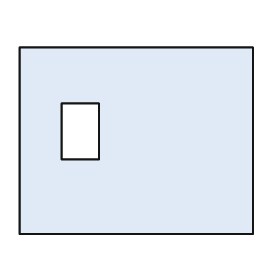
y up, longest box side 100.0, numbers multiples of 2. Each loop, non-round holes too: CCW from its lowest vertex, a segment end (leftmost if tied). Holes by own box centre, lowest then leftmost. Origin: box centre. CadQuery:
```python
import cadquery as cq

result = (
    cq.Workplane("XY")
    .moveTo(-50.0, -40.0)
    .lineTo(50.0, -40.0)
    .lineTo(50.0, 40.0)
    .lineTo(-50.0, 40.0)
    .close()
    .moveTo(-32.0, -8.0)
    .lineTo(-16.0, -8.0)
    .lineTo(-16.0, 16.0)
    .lineTo(-32.0, 16.0)
    .close()
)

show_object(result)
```